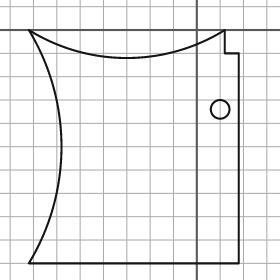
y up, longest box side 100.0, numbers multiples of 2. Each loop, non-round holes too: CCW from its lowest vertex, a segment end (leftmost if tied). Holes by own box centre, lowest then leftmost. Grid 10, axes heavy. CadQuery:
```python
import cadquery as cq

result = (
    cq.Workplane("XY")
    .moveTo(-72.0, -100.0)
    .lineTo(18.0, -100.0)
    .lineTo(18.0, -10.0)
    .lineTo(12.0, -10.0)
    .lineTo(12.0, 0.0)
    .threePointArc((-30.0, -12.0), (-72.0, 0.0))
    .threePointArc((-58.0, -50.0), (-72.0, -100.0))
    .close()
    .moveTo(10.0, -34.0)
    .circle(4.0)
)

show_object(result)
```